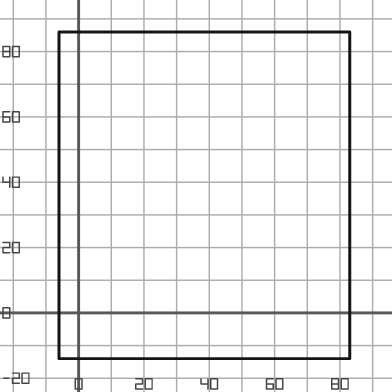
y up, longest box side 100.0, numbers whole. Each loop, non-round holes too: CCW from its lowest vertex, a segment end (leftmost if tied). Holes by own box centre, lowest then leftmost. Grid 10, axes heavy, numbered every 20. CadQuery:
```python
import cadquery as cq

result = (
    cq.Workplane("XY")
    .moveTo(-6.0, -14.0)
    .lineTo(83.0, -14.0)
    .lineTo(83.0, 86.0)
    .lineTo(-6.0, 86.0)
    .close()
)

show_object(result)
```